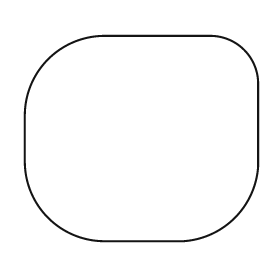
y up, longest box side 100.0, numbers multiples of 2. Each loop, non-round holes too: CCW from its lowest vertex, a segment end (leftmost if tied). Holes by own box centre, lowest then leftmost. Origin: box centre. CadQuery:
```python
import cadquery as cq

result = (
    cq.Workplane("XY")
    .moveTo(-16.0, -44.0)
    .lineTo(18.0, -44.0)
    .threePointArc((40.0, -34.0), (50.0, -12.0))
    .lineTo(50.0, 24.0)
    .threePointArc((44.0, 38.0), (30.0, 44.0))
    .lineTo(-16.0, 44.0)
    .threePointArc((-40.0, 34.0), (-50.0, 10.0))
    .lineTo(-50.0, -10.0)
    .threePointArc((-40.0, -34.0), (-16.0, -44.0))
    .close()
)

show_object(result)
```